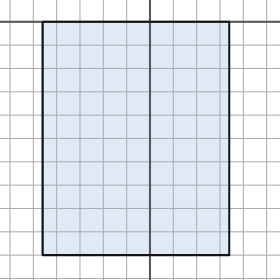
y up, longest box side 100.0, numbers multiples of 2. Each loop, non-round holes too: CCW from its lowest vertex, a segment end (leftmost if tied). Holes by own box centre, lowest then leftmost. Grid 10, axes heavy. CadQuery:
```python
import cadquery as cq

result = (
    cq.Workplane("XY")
    .moveTo(-46.0, -100.0)
    .lineTo(34.0, -100.0)
    .lineTo(34.0, 0.0)
    .lineTo(-46.0, 0.0)
    .close()
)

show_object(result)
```